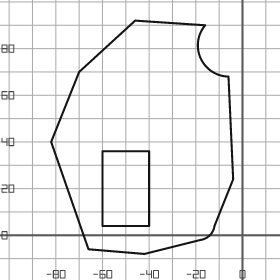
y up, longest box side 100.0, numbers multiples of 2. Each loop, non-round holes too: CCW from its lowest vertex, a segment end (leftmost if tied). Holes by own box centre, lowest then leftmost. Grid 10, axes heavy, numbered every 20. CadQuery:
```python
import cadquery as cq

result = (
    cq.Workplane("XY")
    .moveTo(-42.0, -8.0)
    .lineTo(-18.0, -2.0)
    .threePointArc((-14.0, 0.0), (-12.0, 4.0))
    .lineTo(-4.0, 24.0)
    .lineTo(-6.0, 68.0)
    .threePointArc((-18.0, 76.0), (-16.0, 90.0))
    .lineTo(-46.0, 92.0)
    .lineTo(-70.0, 70.0)
    .lineTo(-82.0, 40.0)
    .lineTo(-66.0, -6.0)
    .close()
    .moveTo(-60.0, 4.0)
    .lineTo(-40.0, 4.0)
    .lineTo(-40.0, 36.0)
    .lineTo(-60.0, 36.0)
    .close()
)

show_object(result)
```